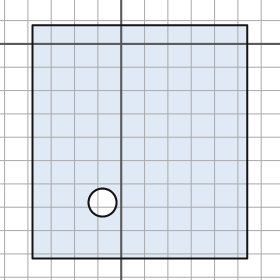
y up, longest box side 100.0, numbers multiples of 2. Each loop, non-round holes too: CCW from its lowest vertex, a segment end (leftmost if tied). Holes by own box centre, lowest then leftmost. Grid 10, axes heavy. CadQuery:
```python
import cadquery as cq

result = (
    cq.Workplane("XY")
    .moveTo(-38.0, -92.0)
    .lineTo(54.0, -92.0)
    .lineTo(54.0, 8.0)
    .lineTo(-38.0, 8.0)
    .close()
    .moveTo(-8.0, -68.0)
    .circle(6.0)
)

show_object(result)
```